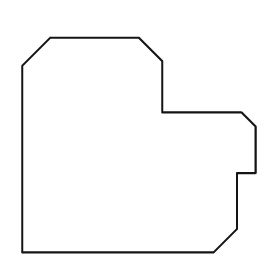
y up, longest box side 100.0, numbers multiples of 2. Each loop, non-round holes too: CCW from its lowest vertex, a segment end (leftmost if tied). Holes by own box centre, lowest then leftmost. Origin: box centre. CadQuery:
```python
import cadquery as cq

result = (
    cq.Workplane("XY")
    .moveTo(-50.0, -46.0)
    .lineTo(32.0, -46.0)
    .lineTo(42.0, -36.0)
    .lineTo(42.0, -12.0)
    .lineTo(50.0, -12.0)
    .lineTo(50.0, 8.0)
    .lineTo(44.0, 14.0)
    .lineTo(10.0, 14.0)
    .lineTo(10.0, 36.0)
    .lineTo(0.0, 46.0)
    .lineTo(-38.0, 46.0)
    .lineTo(-50.0, 34.0)
    .close()
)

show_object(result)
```